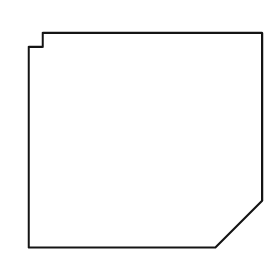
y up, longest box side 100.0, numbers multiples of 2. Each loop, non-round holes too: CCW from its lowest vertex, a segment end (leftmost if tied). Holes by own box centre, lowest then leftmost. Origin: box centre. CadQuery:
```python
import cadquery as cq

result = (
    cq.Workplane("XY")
    .moveTo(-50.0, -46.0)
    .lineTo(30.0, -46.0)
    .lineTo(50.0, -26.0)
    .lineTo(50.0, 46.0)
    .lineTo(-44.0, 46.0)
    .lineTo(-44.0, 40.0)
    .lineTo(-50.0, 40.0)
    .close()
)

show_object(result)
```